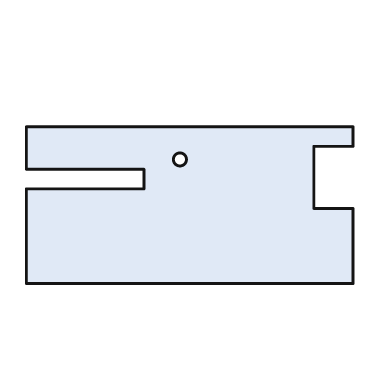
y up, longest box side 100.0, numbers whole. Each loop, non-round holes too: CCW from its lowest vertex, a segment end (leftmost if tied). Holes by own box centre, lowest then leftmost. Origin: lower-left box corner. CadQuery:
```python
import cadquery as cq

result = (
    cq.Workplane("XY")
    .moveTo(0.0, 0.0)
    .lineTo(100.0, 0.0)
    .lineTo(100.0, 23.0)
    .lineTo(88.0, 23.0)
    .lineTo(88.0, 42.0)
    .lineTo(100.0, 42.0)
    .lineTo(100.0, 48.0)
    .lineTo(0.0, 48.0)
    .lineTo(0.0, 35.0)
    .lineTo(36.0, 35.0)
    .lineTo(36.0, 29.0)
    .lineTo(0.0, 29.0)
    .close()
    .moveTo(47.0, 38.0)
    .circle(2.0)
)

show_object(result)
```